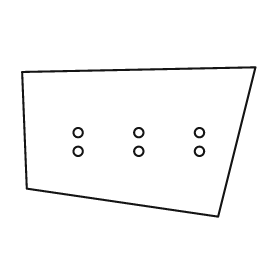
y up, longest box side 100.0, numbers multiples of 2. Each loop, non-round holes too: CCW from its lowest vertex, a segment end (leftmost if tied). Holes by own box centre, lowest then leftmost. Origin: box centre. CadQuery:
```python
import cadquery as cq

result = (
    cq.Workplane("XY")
    .moveTo(34.0, -32.0)
    .lineTo(50.0, 32.0)
    .lineTo(-50.0, 30.0)
    .lineTo(-48.0, -20.0)
    .close()
    .moveTo(-26.0, -4.0)
    .circle(2.0)
    .moveTo(0.0, -4.0)
    .circle(2.0)
    .moveTo(26.0, -4.0)
    .circle(2.0)
    .moveTo(-26.0, 4.0)
    .circle(2.0)
    .moveTo(0.0, 4.0)
    .circle(2.0)
    .moveTo(26.0, 4.0)
    .circle(2.0)
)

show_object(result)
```